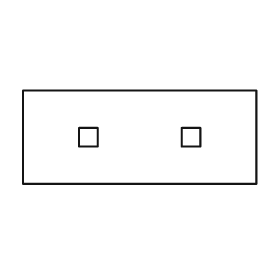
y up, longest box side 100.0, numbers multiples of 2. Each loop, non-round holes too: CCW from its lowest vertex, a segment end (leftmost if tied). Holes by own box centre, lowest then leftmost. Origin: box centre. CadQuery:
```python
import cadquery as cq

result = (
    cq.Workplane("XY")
    .moveTo(-50.0, -20.0)
    .lineTo(50.0, -20.0)
    .lineTo(50.0, 20.0)
    .lineTo(-50.0, 20.0)
    .close()
    .moveTo(-26.0, -4.0)
    .lineTo(-18.0, -4.0)
    .lineTo(-18.0, 4.0)
    .lineTo(-26.0, 4.0)
    .close()
    .moveTo(18.0, -4.0)
    .lineTo(26.0, -4.0)
    .lineTo(26.0, 4.0)
    .lineTo(18.0, 4.0)
    .close()
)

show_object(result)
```